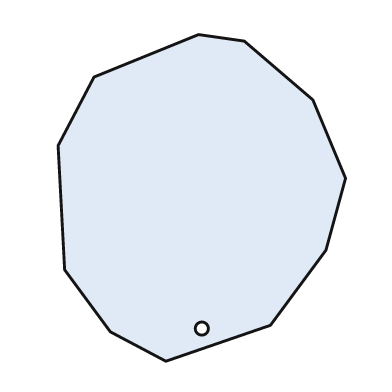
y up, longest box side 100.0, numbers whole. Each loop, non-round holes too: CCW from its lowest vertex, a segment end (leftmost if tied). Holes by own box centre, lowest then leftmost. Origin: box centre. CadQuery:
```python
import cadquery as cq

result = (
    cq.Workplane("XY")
    .moveTo(-11.0, -50.0)
    .lineTo(21.0, -39.0)
    .lineTo(38.0, -16.0)
    .lineTo(44.0, 6.0)
    .lineTo(34.0, 30.0)
    .lineTo(13.0, 48.0)
    .lineTo(-1.0, 50.0)
    .lineTo(-33.0, 37.0)
    .lineTo(-44.0, 16.0)
    .lineTo(-42.0, -22.0)
    .lineTo(-28.0, -41.0)
    .close()
    .moveTo(0.0, -40.0)
    .circle(2.0)
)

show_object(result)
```